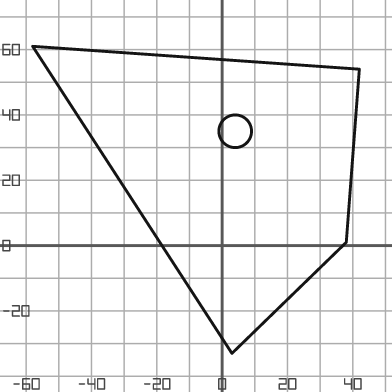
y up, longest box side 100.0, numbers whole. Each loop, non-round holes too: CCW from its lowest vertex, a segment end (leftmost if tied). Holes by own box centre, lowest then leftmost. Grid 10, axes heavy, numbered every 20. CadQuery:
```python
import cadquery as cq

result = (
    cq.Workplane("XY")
    .moveTo(3.0, -33.0)
    .lineTo(38.0, 1.0)
    .lineTo(42.0, 54.0)
    .lineTo(-58.0, 61.0)
    .close()
    .moveTo(4.0, 35.0)
    .circle(5.0)
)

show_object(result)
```